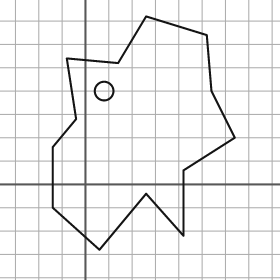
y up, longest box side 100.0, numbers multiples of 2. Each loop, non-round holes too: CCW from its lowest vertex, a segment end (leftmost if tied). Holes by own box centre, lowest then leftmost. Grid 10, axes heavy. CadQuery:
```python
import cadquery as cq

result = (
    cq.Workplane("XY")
    .moveTo(6.0, -28.0)
    .lineTo(26.0, -4.0)
    .lineTo(42.0, -22.0)
    .lineTo(42.0, 6.0)
    .lineTo(64.0, 20.0)
    .lineTo(54.0, 40.0)
    .lineTo(52.0, 64.0)
    .lineTo(26.0, 72.0)
    .lineTo(14.0, 52.0)
    .lineTo(-8.0, 54.0)
    .lineTo(-4.0, 28.0)
    .lineTo(-14.0, 16.0)
    .lineTo(-14.0, -10.0)
    .close()
    .moveTo(8.0, 40.0)
    .circle(4.0)
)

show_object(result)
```